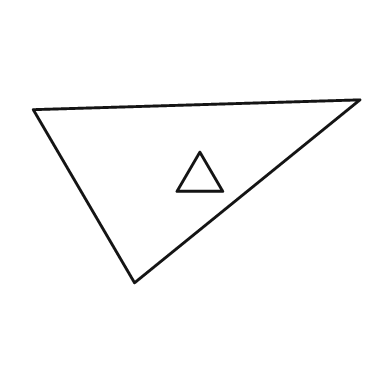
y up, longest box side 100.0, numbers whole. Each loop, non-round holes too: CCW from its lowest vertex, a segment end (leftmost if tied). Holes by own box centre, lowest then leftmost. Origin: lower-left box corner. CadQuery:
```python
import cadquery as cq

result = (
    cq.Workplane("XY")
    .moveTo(31.0, 0.0)
    .lineTo(100.0, 56.0)
    .lineTo(0.0, 53.0)
    .close()
    .moveTo(44.0, 28.0)
    .lineTo(58.0, 28.0)
    .lineTo(51.0, 40.0)
    .close()
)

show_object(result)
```